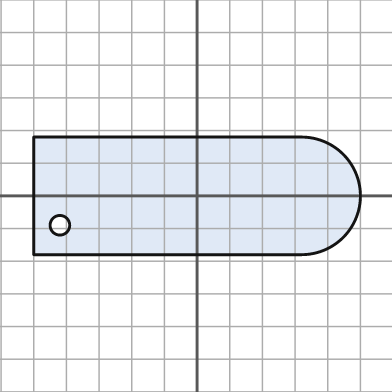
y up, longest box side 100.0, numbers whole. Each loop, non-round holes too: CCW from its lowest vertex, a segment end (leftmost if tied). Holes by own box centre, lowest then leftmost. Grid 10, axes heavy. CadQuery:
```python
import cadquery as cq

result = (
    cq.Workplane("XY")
    .moveTo(-50.0, -18.0)
    .lineTo(32.0, -18.0)
    .threePointArc((50.0, 0.0), (32.0, 18.0))
    .lineTo(-50.0, 18.0)
    .close()
    .moveTo(-42.0, -9.0)
    .circle(3.0)
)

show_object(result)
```